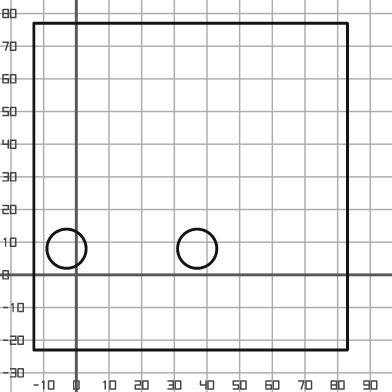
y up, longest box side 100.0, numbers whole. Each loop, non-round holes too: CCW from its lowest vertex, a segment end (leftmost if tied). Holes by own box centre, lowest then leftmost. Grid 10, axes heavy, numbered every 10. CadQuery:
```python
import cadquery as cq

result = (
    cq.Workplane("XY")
    .moveTo(-13.0, -23.0)
    .lineTo(83.0, -23.0)
    .lineTo(83.0, 77.0)
    .lineTo(-13.0, 77.0)
    .close()
    .moveTo(-3.0, 8.0)
    .circle(6.0)
    .moveTo(37.0, 8.0)
    .circle(6.0)
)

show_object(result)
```